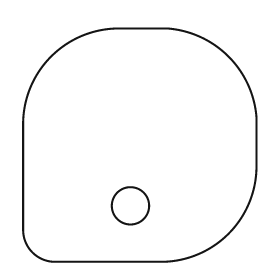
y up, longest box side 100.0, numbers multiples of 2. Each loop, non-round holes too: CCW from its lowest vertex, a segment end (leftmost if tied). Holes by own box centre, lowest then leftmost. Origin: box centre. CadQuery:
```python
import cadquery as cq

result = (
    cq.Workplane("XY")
    .moveTo(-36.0, -50.0)
    .lineTo(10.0, -50.0)
    .threePointArc((38.0, -38.0), (50.0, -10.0))
    .lineTo(50.0, 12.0)
    .threePointArc((38.0, 38.0), (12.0, 50.0))
    .lineTo(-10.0, 50.0)
    .threePointArc((-38.0, 38.0), (-50.0, 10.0))
    .lineTo(-50.0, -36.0)
    .threePointArc((-46.0, -46.0), (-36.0, -50.0))
    .close()
    .moveTo(-4.0, -26.0)
    .circle(8.0)
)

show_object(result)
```